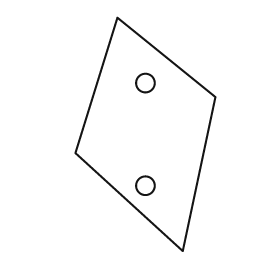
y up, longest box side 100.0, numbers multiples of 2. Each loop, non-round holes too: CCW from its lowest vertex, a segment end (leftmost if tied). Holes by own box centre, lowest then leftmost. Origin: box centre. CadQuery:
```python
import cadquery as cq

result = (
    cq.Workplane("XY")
    .moveTo(16.0, -50.0)
    .lineTo(30.0, 16.0)
    .lineTo(-12.0, 50.0)
    .lineTo(-30.0, -8.0)
    .close()
    .moveTo(0.0, -22.0)
    .circle(4.0)
    .moveTo(0.0, 22.0)
    .circle(4.0)
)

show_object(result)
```